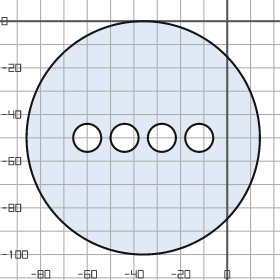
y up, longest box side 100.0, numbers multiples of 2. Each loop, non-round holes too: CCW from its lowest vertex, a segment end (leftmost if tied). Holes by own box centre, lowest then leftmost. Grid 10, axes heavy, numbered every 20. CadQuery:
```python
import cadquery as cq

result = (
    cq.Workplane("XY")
    .moveTo(-36.0, -50.0)
    .circle(50.0)
    .moveTo(-60.0, -50.0)
    .circle(6.0)
    .moveTo(-44.0, -50.0)
    .circle(6.0)
    .moveTo(-28.0, -50.0)
    .circle(6.0)
    .moveTo(-12.0, -50.0)
    .circle(6.0)
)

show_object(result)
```